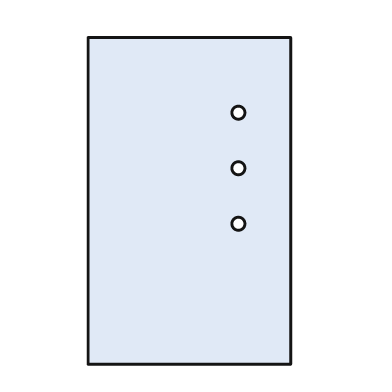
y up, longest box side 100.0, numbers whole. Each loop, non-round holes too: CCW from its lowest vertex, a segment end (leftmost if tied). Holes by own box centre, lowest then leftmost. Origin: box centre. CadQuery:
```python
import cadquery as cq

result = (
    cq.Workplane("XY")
    .moveTo(-31.0, -50.0)
    .lineTo(31.0, -50.0)
    .lineTo(31.0, 50.0)
    .lineTo(-31.0, 50.0)
    .close()
    .moveTo(15.0, -7.0)
    .circle(2.0)
    .moveTo(15.0, 10.0)
    .circle(2.0)
    .moveTo(15.0, 27.0)
    .circle(2.0)
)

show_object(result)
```